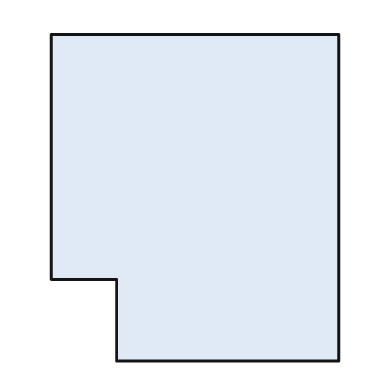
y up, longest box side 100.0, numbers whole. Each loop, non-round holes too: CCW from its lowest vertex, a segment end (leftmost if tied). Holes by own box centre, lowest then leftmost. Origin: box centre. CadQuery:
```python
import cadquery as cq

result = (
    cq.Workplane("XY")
    .moveTo(-24.0, -50.0)
    .lineTo(44.0, -50.0)
    .lineTo(44.0, 50.0)
    .lineTo(-44.0, 50.0)
    .lineTo(-44.0, -25.0)
    .lineTo(-24.0, -25.0)
    .close()
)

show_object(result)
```